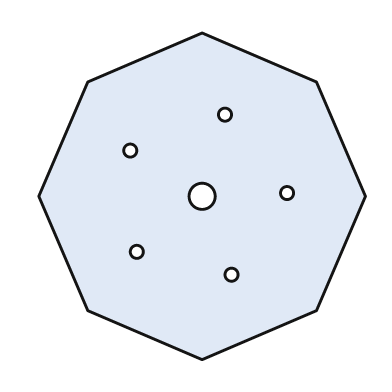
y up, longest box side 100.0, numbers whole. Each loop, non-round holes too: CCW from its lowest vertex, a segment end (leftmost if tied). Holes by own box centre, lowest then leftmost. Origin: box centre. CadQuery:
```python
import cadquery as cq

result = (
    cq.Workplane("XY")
    .moveTo(0.0, -50.0)
    .lineTo(35.0, -35.0)
    .lineTo(50.0, 0.0)
    .lineTo(35.0, 35.0)
    .lineTo(0.0, 50.0)
    .lineTo(-35.0, 35.0)
    .lineTo(-50.0, 0.0)
    .lineTo(-35.0, -35.0)
    .close()
    .moveTo(9.0, -24.0)
    .circle(2.0)
    .moveTo(-20.0, -17.0)
    .circle(2.0)
    .moveTo(0.0, 0.0)
    .circle(4.0)
    .moveTo(26.0, 1.0)
    .circle(2.0)
    .moveTo(-22.0, 14.0)
    .circle(2.0)
    .moveTo(7.0, 25.0)
    .circle(2.0)
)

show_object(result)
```